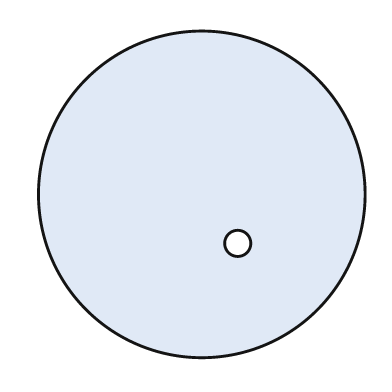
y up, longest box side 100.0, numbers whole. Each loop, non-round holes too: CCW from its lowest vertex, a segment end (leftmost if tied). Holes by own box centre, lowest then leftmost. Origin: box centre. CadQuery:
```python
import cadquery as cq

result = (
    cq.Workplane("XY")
    .moveTo(0.0, 0.0)
    .circle(50.0)
    .moveTo(11.0, -15.0)
    .circle(4.0)
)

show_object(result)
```